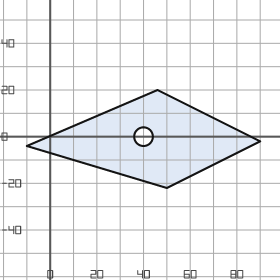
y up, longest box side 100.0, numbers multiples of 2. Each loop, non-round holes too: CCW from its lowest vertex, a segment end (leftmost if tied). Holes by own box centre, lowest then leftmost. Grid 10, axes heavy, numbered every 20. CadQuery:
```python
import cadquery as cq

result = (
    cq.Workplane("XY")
    .moveTo(50.0, -22.0)
    .lineTo(90.0, -2.0)
    .lineTo(46.0, 20.0)
    .lineTo(-10.0, -4.0)
    .close()
    .moveTo(40.0, 0.0)
    .circle(4.0)
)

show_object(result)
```